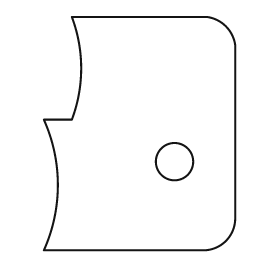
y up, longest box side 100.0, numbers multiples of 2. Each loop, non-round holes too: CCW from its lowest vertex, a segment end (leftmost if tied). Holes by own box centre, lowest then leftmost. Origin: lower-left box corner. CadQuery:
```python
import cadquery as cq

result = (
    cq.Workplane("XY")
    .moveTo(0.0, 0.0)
    .lineTo(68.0, 0.0)
    .threePointArc((78.0, 4.0), (82.0, 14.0))
    .lineTo(82.0, 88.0)
    .threePointArc((78.0, 96.0), (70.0, 100.0))
    .lineTo(12.0, 100.0)
    .threePointArc((16.0, 78.0), (12.0, 56.0))
    .lineTo(0.0, 56.0)
    .threePointArc((6.0, 28.0), (0.0, 0.0))
    .close()
    .moveTo(56.0, 38.0)
    .circle(8.0)
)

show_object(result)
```